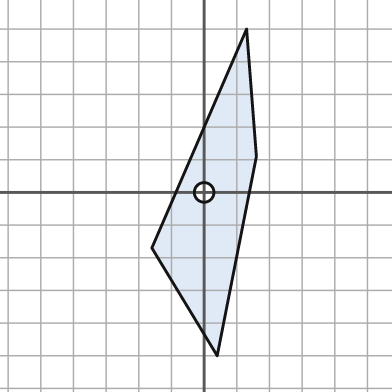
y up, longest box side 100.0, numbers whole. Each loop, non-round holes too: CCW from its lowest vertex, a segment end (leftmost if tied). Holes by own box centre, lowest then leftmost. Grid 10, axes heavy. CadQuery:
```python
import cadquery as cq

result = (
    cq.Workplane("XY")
    .moveTo(4.0, -50.0)
    .lineTo(16.0, 11.0)
    .lineTo(13.0, 50.0)
    .lineTo(-16.0, -17.0)
    .close()
    .moveTo(0.0, 0.0)
    .circle(3.0)
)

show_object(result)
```